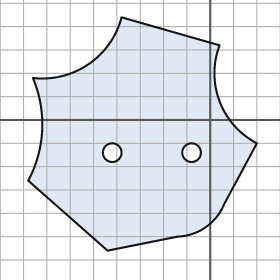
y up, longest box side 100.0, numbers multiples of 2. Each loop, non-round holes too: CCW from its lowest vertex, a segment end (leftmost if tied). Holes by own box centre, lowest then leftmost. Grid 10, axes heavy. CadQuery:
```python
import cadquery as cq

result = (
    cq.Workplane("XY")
    .moveTo(-44.0, -56.0)
    .lineTo(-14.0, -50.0)
    .threePointArc((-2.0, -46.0), (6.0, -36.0))
    .lineTo(20.0, -10.0)
    .threePointArc((4.0, 8.0), (4.0, 32.0))
    .lineTo(-38.0, 44.0)
    .threePointArc((-52.0, 24.0), (-76.0, 18.0))
    .threePointArc((-72.0, -4.0), (-78.0, -26.0))
    .close()
    .moveTo(-42.0, -14.0)
    .circle(4.0)
    .moveTo(-8.0, -14.0)
    .circle(4.0)
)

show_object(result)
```